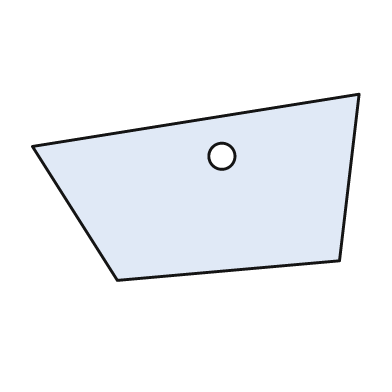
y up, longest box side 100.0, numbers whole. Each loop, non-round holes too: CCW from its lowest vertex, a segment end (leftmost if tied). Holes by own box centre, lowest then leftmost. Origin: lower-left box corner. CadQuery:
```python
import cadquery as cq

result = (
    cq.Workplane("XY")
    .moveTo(26.0, 0.0)
    .lineTo(94.0, 6.0)
    .lineTo(100.0, 57.0)
    .lineTo(0.0, 41.0)
    .close()
    .moveTo(58.0, 38.0)
    .circle(4.0)
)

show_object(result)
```